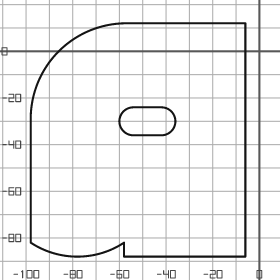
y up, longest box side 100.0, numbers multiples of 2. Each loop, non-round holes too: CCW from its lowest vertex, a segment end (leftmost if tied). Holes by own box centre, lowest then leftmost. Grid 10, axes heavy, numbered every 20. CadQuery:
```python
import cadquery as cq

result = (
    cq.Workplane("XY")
    .moveTo(-58.0, -88.0)
    .lineTo(-6.0, -88.0)
    .lineTo(-6.0, 12.0)
    .lineTo(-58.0, 12.0)
    .threePointArc((-86.0, 0.0), (-98.0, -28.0))
    .lineTo(-98.0, -82.0)
    .threePointArc((-78.0, -88.0), (-58.0, -82.0))
    .close()
    .moveTo(-54.0, -36.0)
    .lineTo(-42.0, -36.0)
    .threePointArc((-36.0, -30.0), (-42.0, -24.0))
    .lineTo(-54.0, -24.0)
    .threePointArc((-60.0, -30.0), (-54.0, -36.0))
    .close()
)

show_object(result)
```